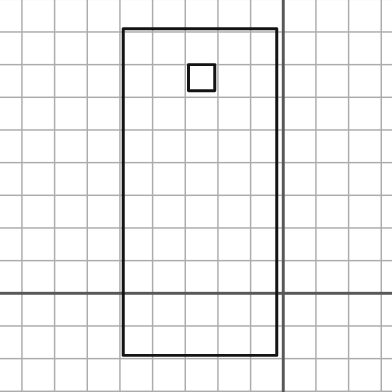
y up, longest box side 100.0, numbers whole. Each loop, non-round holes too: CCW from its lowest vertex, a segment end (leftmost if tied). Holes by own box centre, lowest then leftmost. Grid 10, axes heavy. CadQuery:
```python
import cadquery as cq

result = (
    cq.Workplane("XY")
    .moveTo(-49.0, -19.0)
    .lineTo(-2.0, -19.0)
    .lineTo(-2.0, 81.0)
    .lineTo(-49.0, 81.0)
    .close()
    .moveTo(-29.0, 62.0)
    .lineTo(-21.0, 62.0)
    .lineTo(-21.0, 70.0)
    .lineTo(-29.0, 70.0)
    .close()
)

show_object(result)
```